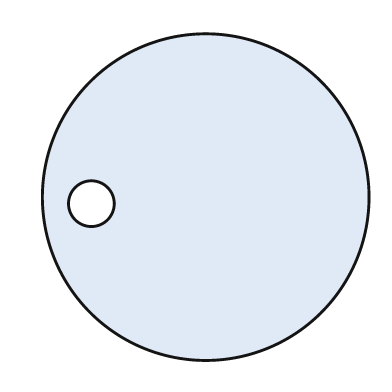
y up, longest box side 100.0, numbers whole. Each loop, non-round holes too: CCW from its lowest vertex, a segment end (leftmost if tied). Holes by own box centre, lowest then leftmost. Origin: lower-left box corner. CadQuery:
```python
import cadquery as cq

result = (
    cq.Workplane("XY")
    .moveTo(50.0, 50.0)
    .circle(50.0)
    .moveTo(15.0, 48.0)
    .circle(7.0)
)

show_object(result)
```